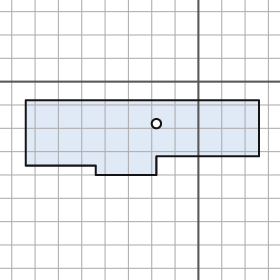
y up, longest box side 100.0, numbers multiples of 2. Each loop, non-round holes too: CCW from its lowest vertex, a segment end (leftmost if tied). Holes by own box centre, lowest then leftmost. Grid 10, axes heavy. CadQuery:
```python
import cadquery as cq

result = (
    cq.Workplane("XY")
    .moveTo(-44.0, -40.0)
    .lineTo(-18.0, -40.0)
    .lineTo(-18.0, -32.0)
    .lineTo(26.0, -32.0)
    .lineTo(26.0, -8.0)
    .lineTo(-74.0, -8.0)
    .lineTo(-74.0, -36.0)
    .lineTo(-44.0, -36.0)
    .close()
    .moveTo(-18.0, -18.0)
    .circle(2.0)
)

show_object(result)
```